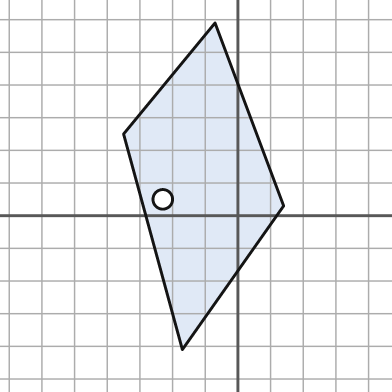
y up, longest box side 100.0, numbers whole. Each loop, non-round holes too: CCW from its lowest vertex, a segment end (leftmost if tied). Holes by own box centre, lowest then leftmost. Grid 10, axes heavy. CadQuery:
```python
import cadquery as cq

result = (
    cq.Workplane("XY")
    .moveTo(-17.0, -41.0)
    .lineTo(14.0, 3.0)
    .lineTo(-7.0, 59.0)
    .lineTo(-35.0, 25.0)
    .close()
    .moveTo(-23.0, 5.0)
    .circle(3.0)
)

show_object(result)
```